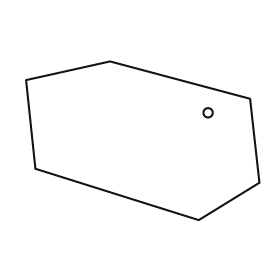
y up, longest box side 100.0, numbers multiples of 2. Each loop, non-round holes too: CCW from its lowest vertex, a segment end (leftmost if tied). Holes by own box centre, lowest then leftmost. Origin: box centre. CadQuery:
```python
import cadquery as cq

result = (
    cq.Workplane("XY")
    .moveTo(24.0, -34.0)
    .lineTo(50.0, -18.0)
    .lineTo(46.0, 18.0)
    .lineTo(-14.0, 34.0)
    .lineTo(-50.0, 26.0)
    .lineTo(-46.0, -12.0)
    .close()
    .moveTo(28.0, 12.0)
    .circle(2.0)
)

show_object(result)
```